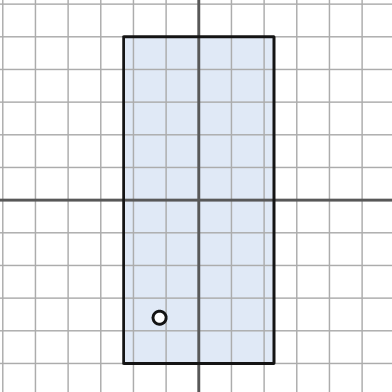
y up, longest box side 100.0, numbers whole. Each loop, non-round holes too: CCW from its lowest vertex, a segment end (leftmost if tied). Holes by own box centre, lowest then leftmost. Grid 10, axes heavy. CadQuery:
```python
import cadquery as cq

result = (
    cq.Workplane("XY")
    .moveTo(-23.0, -50.0)
    .lineTo(23.0, -50.0)
    .lineTo(23.0, 50.0)
    .lineTo(-23.0, 50.0)
    .close()
    .moveTo(-12.0, -36.0)
    .circle(2.0)
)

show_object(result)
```